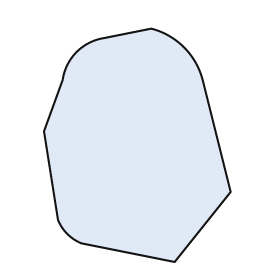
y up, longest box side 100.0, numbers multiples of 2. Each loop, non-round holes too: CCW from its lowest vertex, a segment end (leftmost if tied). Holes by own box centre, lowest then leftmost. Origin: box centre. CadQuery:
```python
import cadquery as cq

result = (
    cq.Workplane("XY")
    .moveTo(16.0, -50.0)
    .lineTo(40.0, -20.0)
    .lineTo(28.0, 28.0)
    .threePointArc((20.0, 42.0), (6.0, 50.0))
    .lineTo(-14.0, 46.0)
    .threePointArc((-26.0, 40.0), (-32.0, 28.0))
    .lineTo(-40.0, 6.0)
    .lineTo(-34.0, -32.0)
    .threePointArc((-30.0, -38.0), (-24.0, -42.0))
    .close()
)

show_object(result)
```